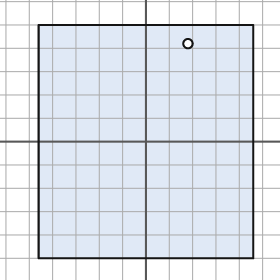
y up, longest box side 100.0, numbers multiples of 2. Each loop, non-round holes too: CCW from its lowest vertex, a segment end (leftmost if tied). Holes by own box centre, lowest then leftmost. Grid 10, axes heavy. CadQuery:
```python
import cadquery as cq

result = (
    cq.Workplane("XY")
    .moveTo(-46.0, -50.0)
    .lineTo(46.0, -50.0)
    .lineTo(46.0, 50.0)
    .lineTo(-46.0, 50.0)
    .close()
    .moveTo(18.0, 42.0)
    .circle(2.0)
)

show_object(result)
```